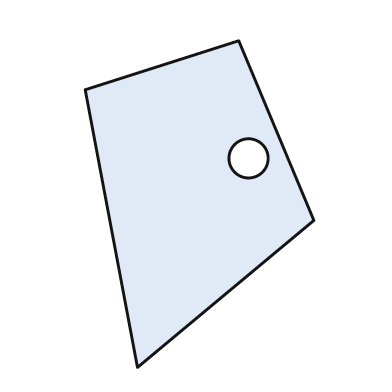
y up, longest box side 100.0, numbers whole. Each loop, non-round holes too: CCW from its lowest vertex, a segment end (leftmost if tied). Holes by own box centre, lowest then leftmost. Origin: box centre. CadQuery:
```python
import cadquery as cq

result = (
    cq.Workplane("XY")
    .moveTo(-19.0, -50.0)
    .lineTo(35.0, -5.0)
    .lineTo(12.0, 50.0)
    .lineTo(-35.0, 35.0)
    .close()
    .moveTo(15.0, 14.0)
    .circle(6.0)
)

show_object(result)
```